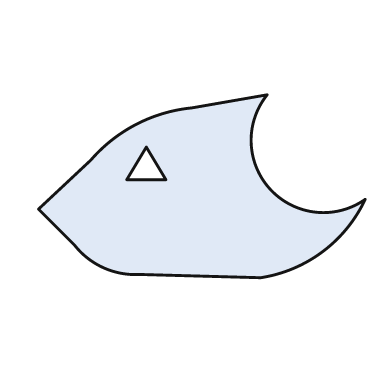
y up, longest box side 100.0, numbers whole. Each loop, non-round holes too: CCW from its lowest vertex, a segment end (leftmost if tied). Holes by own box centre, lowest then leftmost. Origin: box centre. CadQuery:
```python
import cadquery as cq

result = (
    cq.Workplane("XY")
    .moveTo(18.0, -28.0)
    .threePointArc((37.0, -20.0), (50.0, -4.0))
    .threePointArc((21.0, -1.0), (20.0, 28.0))
    .lineTo(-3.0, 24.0)
    .threePointArc((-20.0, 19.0), (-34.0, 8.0))
    .lineTo(-50.0, -7.0)
    .lineTo(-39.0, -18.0)
    .threePointArc((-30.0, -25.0), (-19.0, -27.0))
    .close()
    .moveTo(-23.0, 2.0)
    .lineTo(-11.0, 2.0)
    .lineTo(-17.0, 12.0)
    .close()
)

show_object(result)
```